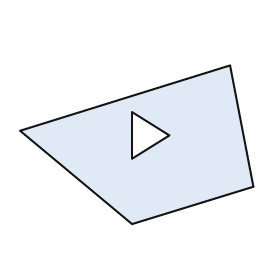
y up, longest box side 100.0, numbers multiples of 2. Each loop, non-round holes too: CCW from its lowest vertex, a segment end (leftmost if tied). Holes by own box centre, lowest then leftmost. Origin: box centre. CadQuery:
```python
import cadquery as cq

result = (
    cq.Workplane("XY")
    .moveTo(-2.0, -34.0)
    .lineTo(50.0, -18.0)
    .lineTo(40.0, 34.0)
    .lineTo(-50.0, 6.0)
    .close()
    .moveTo(-2.0, -6.0)
    .lineTo(14.0, 4.0)
    .lineTo(-2.0, 14.0)
    .close()
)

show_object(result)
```